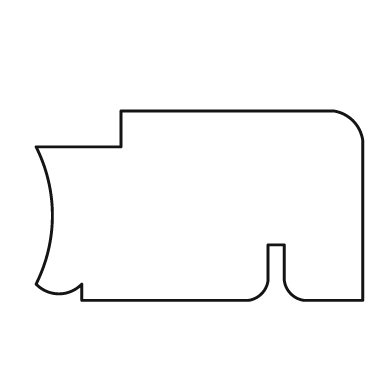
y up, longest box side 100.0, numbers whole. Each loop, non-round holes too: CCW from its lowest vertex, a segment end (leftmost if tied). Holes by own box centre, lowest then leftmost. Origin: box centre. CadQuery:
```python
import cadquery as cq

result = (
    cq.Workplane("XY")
    .moveTo(-36.0, -29.0)
    .lineTo(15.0, -29.0)
    .threePointArc((19.0, -27.0), (21.0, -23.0))
    .lineTo(21.0, -12.0)
    .lineTo(26.0, -12.0)
    .lineTo(26.0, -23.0)
    .threePointArc((28.0, -27.0), (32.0, -29.0))
    .lineTo(50.0, -29.0)
    .lineTo(50.0, 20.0)
    .threePointArc((47.0, 26.0), (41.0, 29.0))
    .lineTo(-24.0, 29.0)
    .lineTo(-24.0, 18.0)
    .lineTo(-50.0, 18.0)
    .threePointArc((-45.0, -3.0), (-50.0, -24.0))
    .threePointArc((-43.0, -27.0), (-36.0, -24.0))
    .close()
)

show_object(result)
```